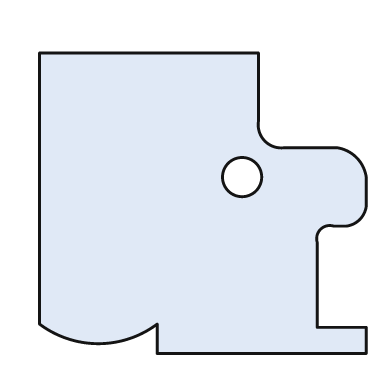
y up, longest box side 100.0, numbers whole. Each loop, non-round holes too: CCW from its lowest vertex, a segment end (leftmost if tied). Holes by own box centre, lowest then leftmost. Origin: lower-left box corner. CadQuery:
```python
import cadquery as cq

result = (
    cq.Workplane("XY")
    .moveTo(36.0, 0.0)
    .lineTo(100.0, 0.0)
    .lineTo(100.0, 8.0)
    .lineTo(85.0, 8.0)
    .lineTo(85.0, 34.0)
    .threePointArc((86.0, 38.0), (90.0, 39.0))
    .lineTo(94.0, 39.0)
    .threePointArc((98.0, 41.0), (100.0, 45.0))
    .lineTo(100.0, 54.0)
    .threePointArc((97.0, 60.0), (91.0, 63.0))
    .lineTo(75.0, 63.0)
    .threePointArc((69.0, 65.0), (67.0, 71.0))
    .lineTo(67.0, 92.0)
    .lineTo(0.0, 92.0)
    .lineTo(0.0, 9.0)
    .threePointArc((18.0, 3.0), (36.0, 9.0))
    .close()
    .moveTo(62.0, 54.0)
    .circle(6.0)
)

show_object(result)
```